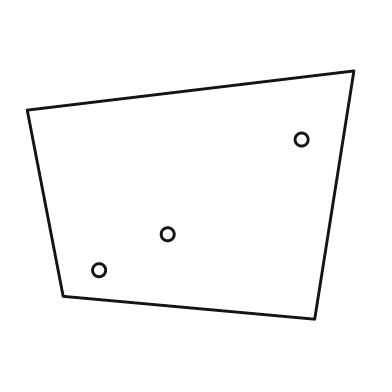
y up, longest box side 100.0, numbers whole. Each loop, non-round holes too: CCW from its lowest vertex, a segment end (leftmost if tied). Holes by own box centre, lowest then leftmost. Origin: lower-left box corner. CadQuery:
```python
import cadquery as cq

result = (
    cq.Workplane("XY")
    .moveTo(88.0, 0.0)
    .lineTo(100.0, 76.0)
    .lineTo(0.0, 64.0)
    .lineTo(11.0, 7.0)
    .close()
    .moveTo(22.0, 15.0)
    .circle(2.0)
    .moveTo(43.0, 26.0)
    .circle(2.0)
    .moveTo(84.0, 55.0)
    .circle(2.0)
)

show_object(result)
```